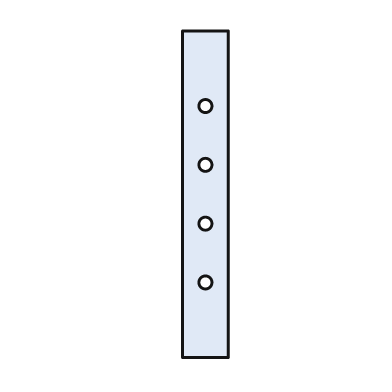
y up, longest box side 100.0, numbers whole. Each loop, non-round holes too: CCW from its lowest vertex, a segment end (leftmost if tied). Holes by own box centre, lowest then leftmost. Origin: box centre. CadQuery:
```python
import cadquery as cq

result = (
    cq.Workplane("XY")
    .moveTo(-7.0, -50.0)
    .lineTo(7.0, -50.0)
    .lineTo(7.0, 50.0)
    .lineTo(-7.0, 50.0)
    .close()
    .moveTo(0.0, -27.0)
    .circle(2.0)
    .moveTo(0.0, -9.0)
    .circle(2.0)
    .moveTo(0.0, 9.0)
    .circle(2.0)
    .moveTo(0.0, 27.0)
    .circle(2.0)
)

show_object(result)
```